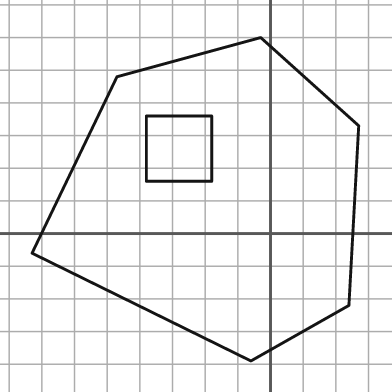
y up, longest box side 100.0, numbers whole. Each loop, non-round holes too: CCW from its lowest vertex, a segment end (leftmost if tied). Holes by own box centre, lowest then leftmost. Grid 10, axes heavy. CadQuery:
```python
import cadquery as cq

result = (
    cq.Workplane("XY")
    .moveTo(-6.0, -39.0)
    .lineTo(24.0, -22.0)
    .lineTo(27.0, 33.0)
    .lineTo(-3.0, 60.0)
    .lineTo(-47.0, 48.0)
    .lineTo(-73.0, -6.0)
    .close()
    .moveTo(-38.0, 16.0)
    .lineTo(-18.0, 16.0)
    .lineTo(-18.0, 36.0)
    .lineTo(-38.0, 36.0)
    .close()
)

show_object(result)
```